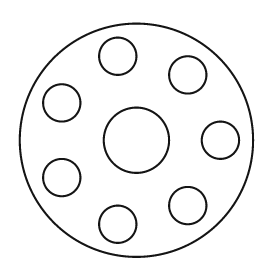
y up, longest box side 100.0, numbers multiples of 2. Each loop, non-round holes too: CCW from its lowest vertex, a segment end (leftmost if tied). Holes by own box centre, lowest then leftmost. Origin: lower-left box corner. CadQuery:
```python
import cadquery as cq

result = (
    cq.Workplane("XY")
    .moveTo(50.0, 50.0)
    .circle(50.0)
    .moveTo(42.0, 14.0)
    .circle(8.0)
    .moveTo(72.0, 22.0)
    .circle(8.0)
    .moveTo(18.0, 34.0)
    .circle(8.0)
    .moveTo(50.0, 50.0)
    .circle(14.0)
    .moveTo(86.0, 50.0)
    .circle(8.0)
    .moveTo(18.0, 66.0)
    .circle(8.0)
    .moveTo(72.0, 78.0)
    .circle(8.0)
    .moveTo(42.0, 86.0)
    .circle(8.0)
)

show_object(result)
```